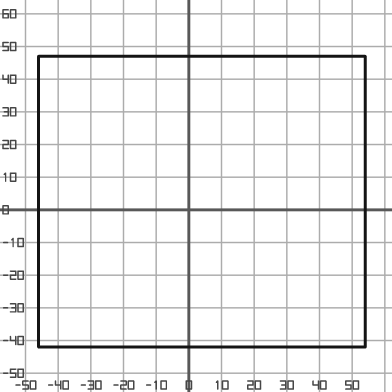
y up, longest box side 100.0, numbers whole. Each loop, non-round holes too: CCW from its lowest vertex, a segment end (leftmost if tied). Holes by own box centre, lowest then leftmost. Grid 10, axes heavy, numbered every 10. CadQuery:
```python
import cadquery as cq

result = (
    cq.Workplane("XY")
    .moveTo(-46.0, -42.0)
    .lineTo(54.0, -42.0)
    .lineTo(54.0, 47.0)
    .lineTo(-46.0, 47.0)
    .close()
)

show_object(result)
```